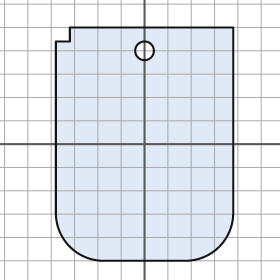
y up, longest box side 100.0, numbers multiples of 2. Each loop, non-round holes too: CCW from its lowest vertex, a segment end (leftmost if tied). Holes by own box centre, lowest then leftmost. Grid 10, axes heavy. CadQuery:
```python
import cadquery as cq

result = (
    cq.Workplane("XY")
    .moveTo(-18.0, -50.0)
    .lineTo(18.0, -50.0)
    .threePointArc((32.0, -44.0), (38.0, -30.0))
    .lineTo(38.0, 50.0)
    .lineTo(-32.0, 50.0)
    .lineTo(-32.0, 44.0)
    .lineTo(-38.0, 44.0)
    .lineTo(-38.0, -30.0)
    .threePointArc((-32.0, -44.0), (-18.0, -50.0))
    .close()
    .moveTo(0.0, 40.0)
    .circle(4.0)
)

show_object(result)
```